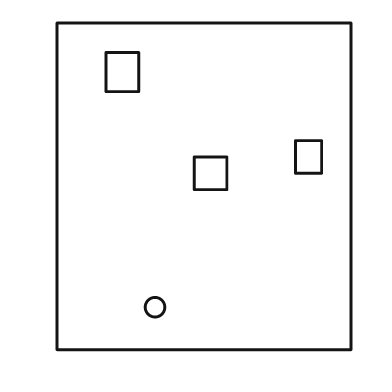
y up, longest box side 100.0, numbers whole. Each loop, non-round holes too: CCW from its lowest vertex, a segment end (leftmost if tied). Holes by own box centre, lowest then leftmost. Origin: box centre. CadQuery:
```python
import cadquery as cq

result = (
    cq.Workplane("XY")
    .moveTo(-45.0, -50.0)
    .lineTo(45.0, -50.0)
    .lineTo(45.0, 50.0)
    .lineTo(-45.0, 50.0)
    .close()
    .moveTo(-15.0, -37.0)
    .circle(3.0)
    .moveTo(-3.0, -1.0)
    .lineTo(7.0, -1.0)
    .lineTo(7.0, 9.0)
    .lineTo(-3.0, 9.0)
    .close()
    .moveTo(28.0, 4.0)
    .lineTo(36.0, 4.0)
    .lineTo(36.0, 14.0)
    .lineTo(28.0, 14.0)
    .close()
    .moveTo(-30.0, 29.0)
    .lineTo(-20.0, 29.0)
    .lineTo(-20.0, 41.0)
    .lineTo(-30.0, 41.0)
    .close()
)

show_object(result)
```